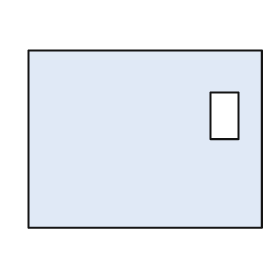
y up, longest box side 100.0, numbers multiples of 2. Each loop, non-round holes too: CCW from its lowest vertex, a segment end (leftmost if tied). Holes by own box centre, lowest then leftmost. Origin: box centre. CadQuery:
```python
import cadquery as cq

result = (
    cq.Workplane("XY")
    .moveTo(-50.0, -38.0)
    .lineTo(50.0, -38.0)
    .lineTo(50.0, 38.0)
    .lineTo(-50.0, 38.0)
    .close()
    .moveTo(28.0, 0.0)
    .lineTo(40.0, 0.0)
    .lineTo(40.0, 20.0)
    .lineTo(28.0, 20.0)
    .close()
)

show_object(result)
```